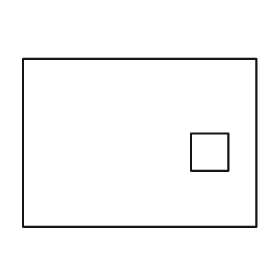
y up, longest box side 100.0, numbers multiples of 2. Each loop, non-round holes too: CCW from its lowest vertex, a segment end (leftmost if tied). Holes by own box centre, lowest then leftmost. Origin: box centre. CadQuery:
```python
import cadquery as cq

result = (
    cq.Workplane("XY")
    .moveTo(-50.0, -36.0)
    .lineTo(50.0, -36.0)
    .lineTo(50.0, 36.0)
    .lineTo(-50.0, 36.0)
    .close()
    .moveTo(22.0, -12.0)
    .lineTo(38.0, -12.0)
    .lineTo(38.0, 4.0)
    .lineTo(22.0, 4.0)
    .close()
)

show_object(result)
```